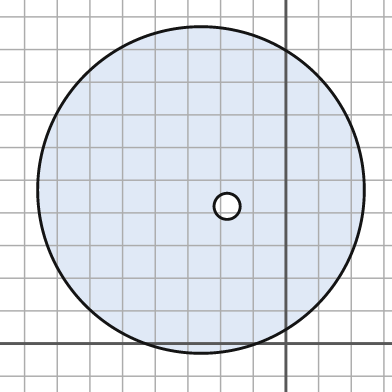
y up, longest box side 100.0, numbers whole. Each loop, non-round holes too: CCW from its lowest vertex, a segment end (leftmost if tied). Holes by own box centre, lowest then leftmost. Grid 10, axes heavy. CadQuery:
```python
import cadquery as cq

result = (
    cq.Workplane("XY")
    .moveTo(-26.0, 47.0)
    .circle(50.0)
    .moveTo(-18.0, 42.0)
    .circle(4.0)
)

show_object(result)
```